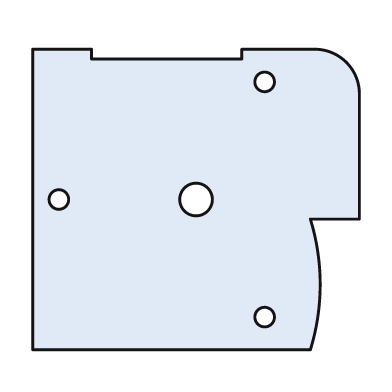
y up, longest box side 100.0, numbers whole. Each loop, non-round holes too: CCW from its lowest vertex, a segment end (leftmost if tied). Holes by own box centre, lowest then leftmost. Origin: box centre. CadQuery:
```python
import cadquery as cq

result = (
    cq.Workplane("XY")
    .moveTo(-50.0, -46.0)
    .lineTo(35.0, -46.0)
    .threePointArc((38.0, -26.0), (35.0, -6.0))
    .lineTo(50.0, -6.0)
    .lineTo(50.0, 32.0)
    .threePointArc((46.0, 42.0), (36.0, 46.0))
    .lineTo(14.0, 46.0)
    .lineTo(14.0, 43.0)
    .lineTo(-32.0, 43.0)
    .lineTo(-32.0, 46.0)
    .lineTo(-50.0, 46.0)
    .close()
    .moveTo(21.0, -36.0)
    .circle(3.0)
    .moveTo(-42.0, 0.0)
    .circle(3.0)
    .moveTo(0.0, 0.0)
    .circle(5.0)
    .moveTo(21.0, 36.0)
    .circle(3.0)
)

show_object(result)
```